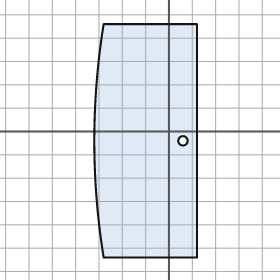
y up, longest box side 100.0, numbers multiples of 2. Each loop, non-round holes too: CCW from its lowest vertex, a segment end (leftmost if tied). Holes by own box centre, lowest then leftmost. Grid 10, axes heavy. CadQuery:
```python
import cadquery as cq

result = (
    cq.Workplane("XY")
    .moveTo(-28.0, -54.0)
    .lineTo(12.0, -54.0)
    .lineTo(12.0, 46.0)
    .lineTo(-28.0, 46.0)
    .threePointArc((-32.0, -4.0), (-28.0, -54.0))
    .close()
    .moveTo(6.0, -4.0)
    .circle(2.0)
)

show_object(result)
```